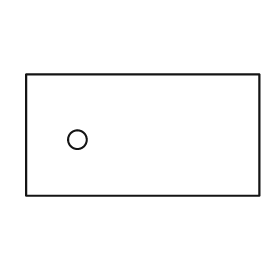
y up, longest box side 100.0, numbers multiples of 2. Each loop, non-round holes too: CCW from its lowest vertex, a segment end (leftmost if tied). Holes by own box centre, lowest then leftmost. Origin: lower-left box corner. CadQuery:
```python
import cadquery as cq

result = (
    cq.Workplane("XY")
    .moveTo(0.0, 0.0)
    .lineTo(100.0, 0.0)
    .lineTo(100.0, 52.0)
    .lineTo(0.0, 52.0)
    .close()
    .moveTo(22.0, 24.0)
    .circle(4.0)
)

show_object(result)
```